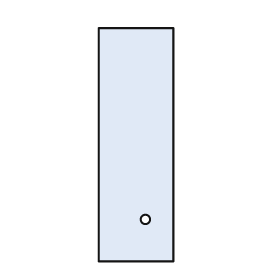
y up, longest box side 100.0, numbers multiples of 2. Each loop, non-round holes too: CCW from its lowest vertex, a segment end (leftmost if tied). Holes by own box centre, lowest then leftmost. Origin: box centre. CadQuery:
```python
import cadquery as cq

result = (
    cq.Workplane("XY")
    .moveTo(-16.0, -50.0)
    .lineTo(16.0, -50.0)
    .lineTo(16.0, 50.0)
    .lineTo(-16.0, 50.0)
    .close()
    .moveTo(4.0, -32.0)
    .circle(2.0)
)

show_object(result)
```